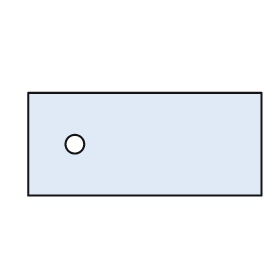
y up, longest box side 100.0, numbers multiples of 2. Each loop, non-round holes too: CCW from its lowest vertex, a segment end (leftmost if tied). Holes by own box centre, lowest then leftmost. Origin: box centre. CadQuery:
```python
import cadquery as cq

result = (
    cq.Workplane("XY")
    .moveTo(-50.0, -22.0)
    .lineTo(50.0, -22.0)
    .lineTo(50.0, 22.0)
    .lineTo(-50.0, 22.0)
    .close()
    .moveTo(-30.0, 0.0)
    .circle(4.0)
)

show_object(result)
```